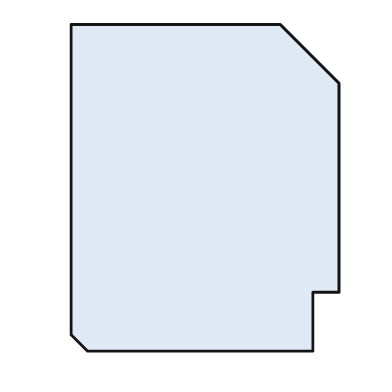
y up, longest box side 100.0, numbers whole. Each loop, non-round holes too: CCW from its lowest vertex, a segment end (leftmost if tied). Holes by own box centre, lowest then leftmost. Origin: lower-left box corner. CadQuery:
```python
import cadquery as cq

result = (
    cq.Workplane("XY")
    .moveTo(5.0, 0.0)
    .lineTo(74.0, 0.0)
    .lineTo(74.0, 18.0)
    .lineTo(82.0, 18.0)
    .lineTo(82.0, 82.0)
    .lineTo(64.0, 100.0)
    .lineTo(0.0, 100.0)
    .lineTo(0.0, 5.0)
    .close()
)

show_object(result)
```